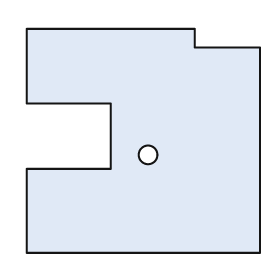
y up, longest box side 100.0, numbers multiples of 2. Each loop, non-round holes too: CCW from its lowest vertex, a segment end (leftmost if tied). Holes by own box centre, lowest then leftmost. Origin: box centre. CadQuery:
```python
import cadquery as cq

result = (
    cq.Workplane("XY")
    .moveTo(-50.0, -48.0)
    .lineTo(50.0, -48.0)
    .lineTo(50.0, 40.0)
    .lineTo(22.0, 40.0)
    .lineTo(22.0, 48.0)
    .lineTo(-50.0, 48.0)
    .lineTo(-50.0, 16.0)
    .lineTo(-14.0, 16.0)
    .lineTo(-14.0, -12.0)
    .lineTo(-50.0, -12.0)
    .close()
    .moveTo(2.0, -6.0)
    .circle(4.0)
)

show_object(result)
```